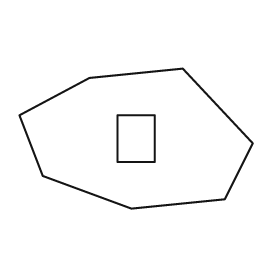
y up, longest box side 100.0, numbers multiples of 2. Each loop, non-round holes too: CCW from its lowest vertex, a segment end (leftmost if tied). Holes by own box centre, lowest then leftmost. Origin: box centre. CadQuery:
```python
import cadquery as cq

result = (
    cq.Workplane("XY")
    .moveTo(-2.0, -30.0)
    .lineTo(38.0, -26.0)
    .lineTo(50.0, -2.0)
    .lineTo(20.0, 30.0)
    .lineTo(-20.0, 26.0)
    .lineTo(-50.0, 10.0)
    .lineTo(-40.0, -16.0)
    .close()
    .moveTo(-8.0, -10.0)
    .lineTo(8.0, -10.0)
    .lineTo(8.0, 10.0)
    .lineTo(-8.0, 10.0)
    .close()
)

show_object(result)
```